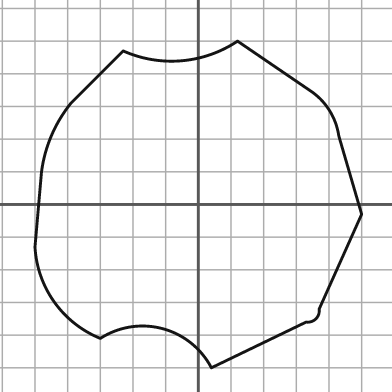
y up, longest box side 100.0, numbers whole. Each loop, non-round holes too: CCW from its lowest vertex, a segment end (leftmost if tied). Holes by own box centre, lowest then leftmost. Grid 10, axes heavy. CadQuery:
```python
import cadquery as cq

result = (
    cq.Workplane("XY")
    .moveTo(4.0, -50.0)
    .lineTo(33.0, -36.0)
    .threePointArc((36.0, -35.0), (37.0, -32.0))
    .lineTo(50.0, -3.0)
    .lineTo(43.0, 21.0)
    .threePointArc((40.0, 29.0), (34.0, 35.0))
    .lineTo(12.0, 50.0)
    .threePointArc((-5.0, 44.0), (-23.0, 47.0))
    .lineTo(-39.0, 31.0)
    .threePointArc((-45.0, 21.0), (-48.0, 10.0))
    .lineTo(-50.0, -13.0)
    .threePointArc((-44.0, -30.0), (-30.0, -41.0))
    .threePointArc((-11.0, -38.0), (4.0, -50.0))
    .close()
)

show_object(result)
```